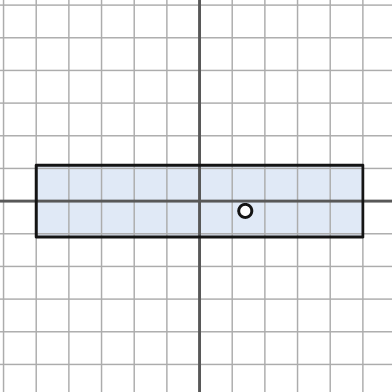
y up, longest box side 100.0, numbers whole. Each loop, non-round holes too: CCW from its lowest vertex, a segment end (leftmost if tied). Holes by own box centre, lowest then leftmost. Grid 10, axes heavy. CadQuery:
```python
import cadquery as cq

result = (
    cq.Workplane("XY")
    .moveTo(-50.0, -11.0)
    .lineTo(50.0, -11.0)
    .lineTo(50.0, 11.0)
    .lineTo(-50.0, 11.0)
    .close()
    .moveTo(14.0, -3.0)
    .circle(2.0)
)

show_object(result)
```